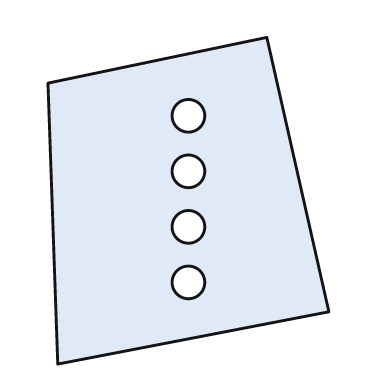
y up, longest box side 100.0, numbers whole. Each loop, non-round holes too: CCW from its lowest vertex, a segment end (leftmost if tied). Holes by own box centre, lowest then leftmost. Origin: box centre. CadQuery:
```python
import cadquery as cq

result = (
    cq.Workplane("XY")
    .moveTo(-40.0, -50.0)
    .lineTo(43.0, -34.0)
    .lineTo(24.0, 50.0)
    .lineTo(-43.0, 36.0)
    .close()
    .moveTo(0.0, -25.0)
    .circle(5.0)
    .moveTo(0.0, -8.0)
    .circle(5.0)
    .moveTo(0.0, 9.0)
    .circle(5.0)
    .moveTo(0.0, 26.0)
    .circle(5.0)
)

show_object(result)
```